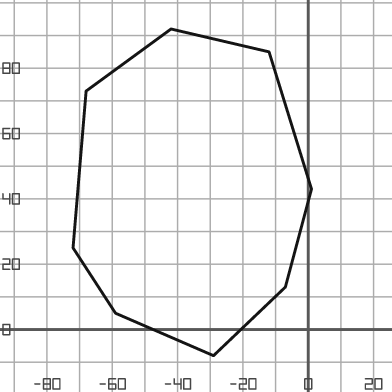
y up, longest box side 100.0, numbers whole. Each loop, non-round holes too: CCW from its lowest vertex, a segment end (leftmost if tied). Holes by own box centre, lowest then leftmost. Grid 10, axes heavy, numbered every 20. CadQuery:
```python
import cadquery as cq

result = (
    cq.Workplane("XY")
    .moveTo(-29.0, -8.0)
    .lineTo(-7.0, 13.0)
    .lineTo(1.0, 43.0)
    .lineTo(-12.0, 85.0)
    .lineTo(-42.0, 92.0)
    .lineTo(-68.0, 73.0)
    .lineTo(-72.0, 25.0)
    .lineTo(-59.0, 5.0)
    .close()
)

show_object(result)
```